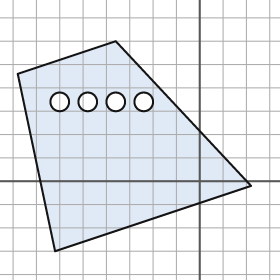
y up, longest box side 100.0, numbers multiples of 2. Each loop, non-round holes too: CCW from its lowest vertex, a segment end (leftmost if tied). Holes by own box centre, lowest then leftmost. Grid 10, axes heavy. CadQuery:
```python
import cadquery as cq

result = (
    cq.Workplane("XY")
    .moveTo(-62.0, -30.0)
    .lineTo(22.0, -2.0)
    .lineTo(-36.0, 60.0)
    .lineTo(-78.0, 46.0)
    .close()
    .moveTo(-60.0, 34.0)
    .circle(4.0)
    .moveTo(-48.0, 34.0)
    .circle(4.0)
    .moveTo(-36.0, 34.0)
    .circle(4.0)
    .moveTo(-24.0, 34.0)
    .circle(4.0)
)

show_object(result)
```